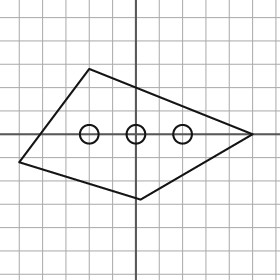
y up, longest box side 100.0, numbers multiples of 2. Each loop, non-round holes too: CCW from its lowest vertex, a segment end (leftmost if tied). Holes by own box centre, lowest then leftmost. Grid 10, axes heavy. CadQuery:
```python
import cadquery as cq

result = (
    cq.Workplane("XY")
    .moveTo(2.0, -28.0)
    .lineTo(50.0, 0.0)
    .lineTo(-20.0, 28.0)
    .lineTo(-50.0, -12.0)
    .close()
    .moveTo(-20.0, 0.0)
    .circle(4.0)
    .moveTo(0.0, 0.0)
    .circle(4.0)
    .moveTo(20.0, 0.0)
    .circle(4.0)
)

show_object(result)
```